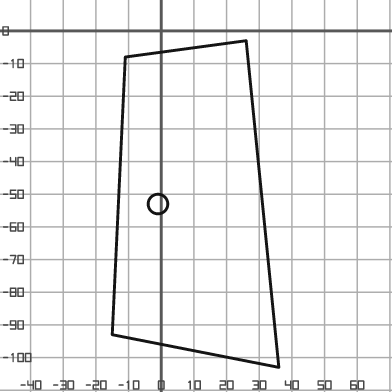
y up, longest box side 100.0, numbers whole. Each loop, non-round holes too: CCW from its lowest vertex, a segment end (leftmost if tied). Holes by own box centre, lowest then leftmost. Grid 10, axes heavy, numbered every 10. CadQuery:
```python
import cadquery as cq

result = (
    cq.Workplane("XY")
    .moveTo(36.0, -103.0)
    .lineTo(26.0, -3.0)
    .lineTo(-11.0, -8.0)
    .lineTo(-15.0, -93.0)
    .close()
    .moveTo(-1.0, -53.0)
    .circle(3.0)
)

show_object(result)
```